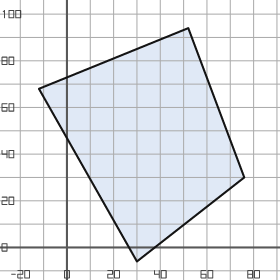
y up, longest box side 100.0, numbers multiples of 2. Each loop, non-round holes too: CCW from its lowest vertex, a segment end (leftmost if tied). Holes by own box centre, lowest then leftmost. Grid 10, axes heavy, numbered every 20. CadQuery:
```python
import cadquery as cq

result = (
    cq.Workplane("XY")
    .moveTo(30.0, -6.0)
    .lineTo(76.0, 30.0)
    .lineTo(52.0, 94.0)
    .lineTo(-12.0, 68.0)
    .close()
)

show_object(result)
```